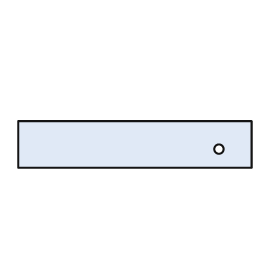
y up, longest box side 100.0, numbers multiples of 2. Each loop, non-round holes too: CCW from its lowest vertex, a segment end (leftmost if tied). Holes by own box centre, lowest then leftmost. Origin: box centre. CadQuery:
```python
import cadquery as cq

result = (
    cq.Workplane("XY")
    .moveTo(-50.0, -10.0)
    .lineTo(50.0, -10.0)
    .lineTo(50.0, 10.0)
    .lineTo(-50.0, 10.0)
    .close()
    .moveTo(36.0, -2.0)
    .circle(2.0)
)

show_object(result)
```